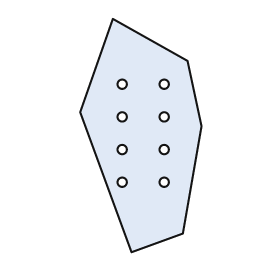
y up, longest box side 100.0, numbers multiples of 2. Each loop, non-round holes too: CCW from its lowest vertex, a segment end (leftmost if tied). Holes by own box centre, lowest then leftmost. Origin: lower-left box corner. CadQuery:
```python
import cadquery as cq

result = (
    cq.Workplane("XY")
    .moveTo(22.0, 0.0)
    .lineTo(44.0, 8.0)
    .lineTo(52.0, 54.0)
    .lineTo(46.0, 82.0)
    .lineTo(14.0, 100.0)
    .lineTo(0.0, 60.0)
    .close()
    .moveTo(18.0, 30.0)
    .circle(2.0)
    .moveTo(36.0, 30.0)
    .circle(2.0)
    .moveTo(18.0, 44.0)
    .circle(2.0)
    .moveTo(36.0, 44.0)
    .circle(2.0)
    .moveTo(18.0, 58.0)
    .circle(2.0)
    .moveTo(36.0, 58.0)
    .circle(2.0)
    .moveTo(18.0, 72.0)
    .circle(2.0)
    .moveTo(36.0, 72.0)
    .circle(2.0)
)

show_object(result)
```